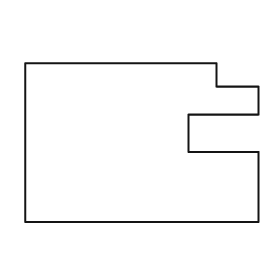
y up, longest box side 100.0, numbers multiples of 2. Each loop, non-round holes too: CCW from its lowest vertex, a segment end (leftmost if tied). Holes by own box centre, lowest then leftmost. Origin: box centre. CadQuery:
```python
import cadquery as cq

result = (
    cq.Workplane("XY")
    .moveTo(-50.0, -34.0)
    .lineTo(50.0, -34.0)
    .lineTo(50.0, -4.0)
    .lineTo(20.0, -4.0)
    .lineTo(20.0, 12.0)
    .lineTo(50.0, 12.0)
    .lineTo(50.0, 24.0)
    .lineTo(32.0, 24.0)
    .lineTo(32.0, 34.0)
    .lineTo(-50.0, 34.0)
    .close()
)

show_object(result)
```